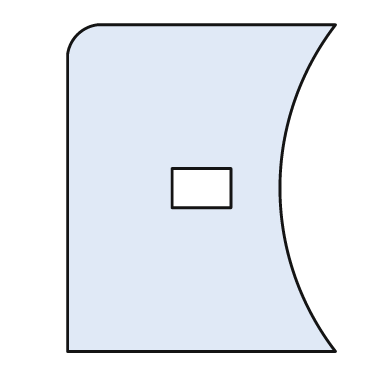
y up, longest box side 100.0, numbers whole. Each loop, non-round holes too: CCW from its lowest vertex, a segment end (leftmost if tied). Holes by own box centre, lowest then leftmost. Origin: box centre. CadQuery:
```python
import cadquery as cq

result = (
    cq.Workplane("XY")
    .moveTo(-41.0, -50.0)
    .lineTo(41.0, -50.0)
    .threePointArc((24.0, 0.0), (41.0, 50.0))
    .lineTo(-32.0, 50.0)
    .threePointArc((-38.0, 47.0), (-41.0, 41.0))
    .close()
    .moveTo(-9.0, -6.0)
    .lineTo(9.0, -6.0)
    .lineTo(9.0, 6.0)
    .lineTo(-9.0, 6.0)
    .close()
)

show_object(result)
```